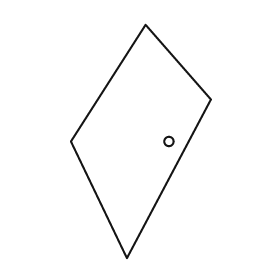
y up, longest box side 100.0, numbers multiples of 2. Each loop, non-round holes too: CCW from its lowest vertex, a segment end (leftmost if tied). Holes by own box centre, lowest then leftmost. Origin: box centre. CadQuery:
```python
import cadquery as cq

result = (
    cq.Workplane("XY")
    .moveTo(-6.0, -50.0)
    .lineTo(30.0, 18.0)
    .lineTo(2.0, 50.0)
    .lineTo(-30.0, 0.0)
    .close()
    .moveTo(12.0, 0.0)
    .circle(2.0)
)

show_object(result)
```